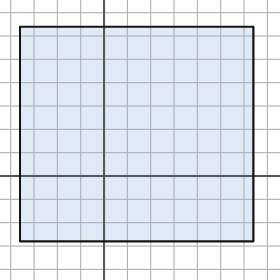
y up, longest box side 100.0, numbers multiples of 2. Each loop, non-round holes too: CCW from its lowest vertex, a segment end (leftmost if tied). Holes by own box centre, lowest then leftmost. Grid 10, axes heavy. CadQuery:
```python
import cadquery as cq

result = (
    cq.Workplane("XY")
    .moveTo(-36.0, -28.0)
    .lineTo(64.0, -28.0)
    .lineTo(64.0, 64.0)
    .lineTo(-36.0, 64.0)
    .close()
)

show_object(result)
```